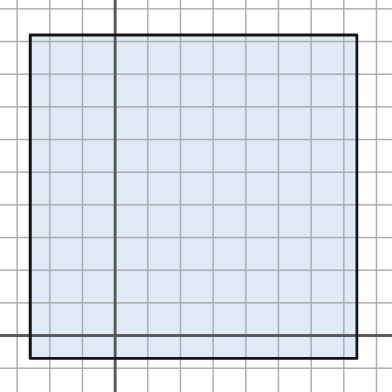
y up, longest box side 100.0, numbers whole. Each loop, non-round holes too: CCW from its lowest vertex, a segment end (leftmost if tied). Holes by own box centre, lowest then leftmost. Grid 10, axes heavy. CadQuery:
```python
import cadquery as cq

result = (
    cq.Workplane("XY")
    .moveTo(-26.0, -7.0)
    .lineTo(74.0, -7.0)
    .lineTo(74.0, 92.0)
    .lineTo(-26.0, 92.0)
    .close()
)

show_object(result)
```